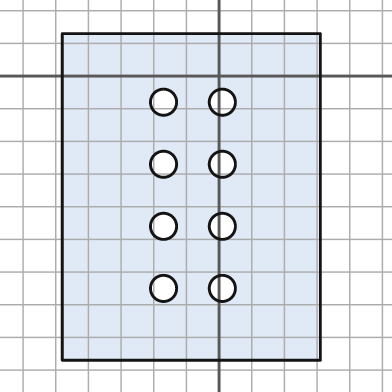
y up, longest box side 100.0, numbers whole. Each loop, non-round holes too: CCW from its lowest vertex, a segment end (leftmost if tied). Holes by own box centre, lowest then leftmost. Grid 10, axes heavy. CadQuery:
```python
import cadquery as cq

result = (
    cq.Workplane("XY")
    .moveTo(-48.0, -87.0)
    .lineTo(31.0, -87.0)
    .lineTo(31.0, 13.0)
    .lineTo(-48.0, 13.0)
    .close()
    .moveTo(-17.0, -65.0)
    .circle(4.0)
    .moveTo(1.0, -65.0)
    .circle(4.0)
    .moveTo(-17.0, -46.0)
    .circle(4.0)
    .moveTo(1.0, -46.0)
    .circle(4.0)
    .moveTo(-17.0, -27.0)
    .circle(4.0)
    .moveTo(1.0, -27.0)
    .circle(4.0)
    .moveTo(-17.0, -8.0)
    .circle(4.0)
    .moveTo(1.0, -8.0)
    .circle(4.0)
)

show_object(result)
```